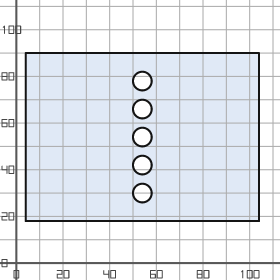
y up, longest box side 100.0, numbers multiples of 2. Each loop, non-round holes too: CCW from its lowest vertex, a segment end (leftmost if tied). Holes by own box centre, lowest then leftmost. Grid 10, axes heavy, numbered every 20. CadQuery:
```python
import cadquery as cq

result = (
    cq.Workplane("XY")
    .moveTo(4.0, 18.0)
    .lineTo(104.0, 18.0)
    .lineTo(104.0, 90.0)
    .lineTo(4.0, 90.0)
    .close()
    .moveTo(54.0, 30.0)
    .circle(4.0)
    .moveTo(54.0, 42.0)
    .circle(4.0)
    .moveTo(54.0, 54.0)
    .circle(4.0)
    .moveTo(54.0, 66.0)
    .circle(4.0)
    .moveTo(54.0, 78.0)
    .circle(4.0)
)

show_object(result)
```